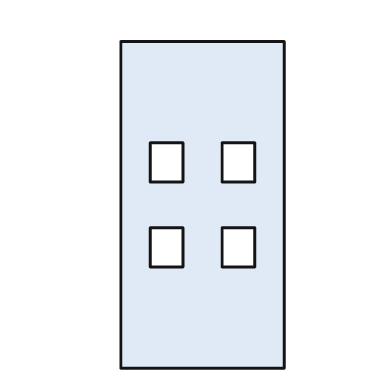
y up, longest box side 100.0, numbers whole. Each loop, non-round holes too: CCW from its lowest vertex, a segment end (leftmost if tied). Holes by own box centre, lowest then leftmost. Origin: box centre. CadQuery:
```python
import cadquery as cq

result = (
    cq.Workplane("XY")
    .moveTo(-25.0, -50.0)
    .lineTo(25.0, -50.0)
    .lineTo(25.0, 50.0)
    .lineTo(-25.0, 50.0)
    .close()
    .moveTo(-16.0, -19.0)
    .lineTo(-6.0, -19.0)
    .lineTo(-6.0, -7.0)
    .lineTo(-16.0, -7.0)
    .close()
    .moveTo(6.0, -19.0)
    .lineTo(16.0, -19.0)
    .lineTo(16.0, -7.0)
    .lineTo(6.0, -7.0)
    .close()
    .moveTo(-16.0, 7.0)
    .lineTo(-6.0, 7.0)
    .lineTo(-6.0, 19.0)
    .lineTo(-16.0, 19.0)
    .close()
    .moveTo(6.0, 7.0)
    .lineTo(16.0, 7.0)
    .lineTo(16.0, 19.0)
    .lineTo(6.0, 19.0)
    .close()
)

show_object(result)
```